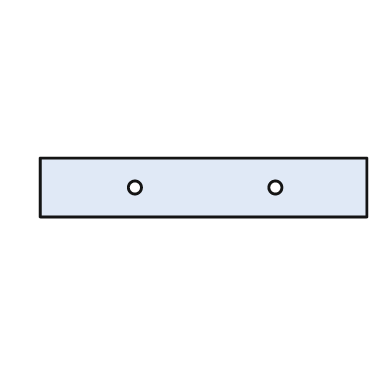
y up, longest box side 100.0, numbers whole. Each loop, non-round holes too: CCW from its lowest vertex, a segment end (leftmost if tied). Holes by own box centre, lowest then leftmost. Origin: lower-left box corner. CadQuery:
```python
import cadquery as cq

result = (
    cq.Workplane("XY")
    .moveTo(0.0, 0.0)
    .lineTo(100.0, 0.0)
    .lineTo(100.0, 18.0)
    .lineTo(0.0, 18.0)
    .close()
    .moveTo(29.0, 9.0)
    .circle(2.0)
    .moveTo(72.0, 9.0)
    .circle(2.0)
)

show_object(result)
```